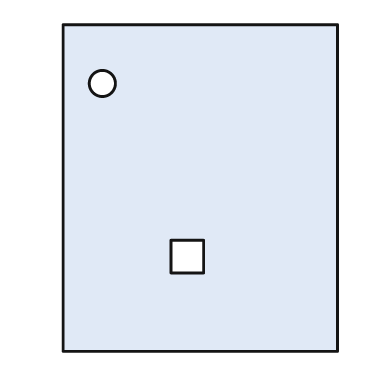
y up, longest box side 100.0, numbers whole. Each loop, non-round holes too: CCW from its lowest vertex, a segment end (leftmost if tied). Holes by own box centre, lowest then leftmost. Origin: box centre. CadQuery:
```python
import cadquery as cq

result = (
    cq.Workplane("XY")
    .moveTo(-42.0, -50.0)
    .lineTo(42.0, -50.0)
    .lineTo(42.0, 50.0)
    .lineTo(-42.0, 50.0)
    .close()
    .moveTo(-9.0, -26.0)
    .lineTo(1.0, -26.0)
    .lineTo(1.0, -16.0)
    .lineTo(-9.0, -16.0)
    .close()
    .moveTo(-30.0, 32.0)
    .circle(4.0)
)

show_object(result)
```